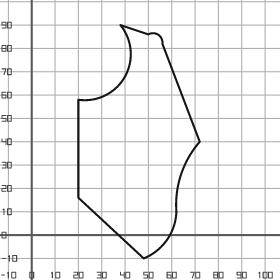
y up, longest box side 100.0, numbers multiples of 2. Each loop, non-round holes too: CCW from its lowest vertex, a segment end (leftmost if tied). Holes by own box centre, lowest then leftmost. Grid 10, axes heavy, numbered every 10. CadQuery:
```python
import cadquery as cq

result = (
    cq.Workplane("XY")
    .moveTo(48.0, -10.0)
    .threePointArc((58.0, -2.0), (62.0, 10.0))
    .threePointArc((64.0, 26.0), (72.0, 40.0))
    .lineTo(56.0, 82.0)
    .threePointArc((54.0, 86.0), (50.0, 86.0))
    .lineTo(38.0, 90.0)
    .threePointArc((40.0, 68.0), (20.0, 58.0))
    .lineTo(20.0, 16.0)
    .close()
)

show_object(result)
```